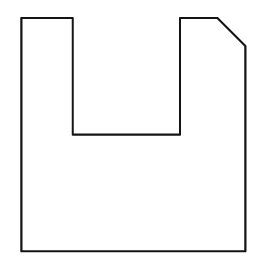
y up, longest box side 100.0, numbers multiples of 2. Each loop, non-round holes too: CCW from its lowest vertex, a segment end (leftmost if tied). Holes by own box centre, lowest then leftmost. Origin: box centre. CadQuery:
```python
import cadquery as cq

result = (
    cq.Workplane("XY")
    .moveTo(-48.0, -50.0)
    .lineTo(48.0, -50.0)
    .lineTo(48.0, 38.0)
    .lineTo(36.0, 50.0)
    .lineTo(20.0, 50.0)
    .lineTo(20.0, 0.0)
    .lineTo(-26.0, 0.0)
    .lineTo(-26.0, 50.0)
    .lineTo(-48.0, 50.0)
    .close()
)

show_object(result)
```